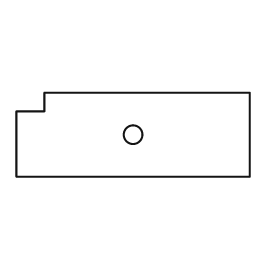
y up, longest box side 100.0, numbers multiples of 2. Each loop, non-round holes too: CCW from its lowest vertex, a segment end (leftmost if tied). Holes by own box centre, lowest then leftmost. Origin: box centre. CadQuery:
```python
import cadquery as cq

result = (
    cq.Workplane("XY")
    .moveTo(-50.0, -18.0)
    .lineTo(50.0, -18.0)
    .lineTo(50.0, 18.0)
    .lineTo(-38.0, 18.0)
    .lineTo(-38.0, 10.0)
    .lineTo(-50.0, 10.0)
    .close()
    .moveTo(0.0, 0.0)
    .circle(4.0)
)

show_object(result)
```